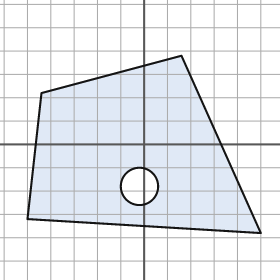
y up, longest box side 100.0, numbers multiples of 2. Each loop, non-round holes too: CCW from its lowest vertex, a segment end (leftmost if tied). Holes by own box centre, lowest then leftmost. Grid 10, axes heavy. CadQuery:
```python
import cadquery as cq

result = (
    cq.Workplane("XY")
    .moveTo(50.0, -38.0)
    .lineTo(16.0, 38.0)
    .lineTo(-44.0, 22.0)
    .lineTo(-50.0, -32.0)
    .close()
    .moveTo(-2.0, -18.0)
    .circle(8.0)
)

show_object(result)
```